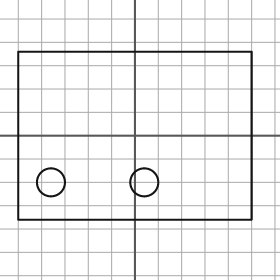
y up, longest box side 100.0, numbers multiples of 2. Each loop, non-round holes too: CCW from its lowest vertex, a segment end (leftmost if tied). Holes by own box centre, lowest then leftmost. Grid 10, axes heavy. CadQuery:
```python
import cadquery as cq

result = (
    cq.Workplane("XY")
    .moveTo(-50.0, -36.0)
    .lineTo(50.0, -36.0)
    .lineTo(50.0, 36.0)
    .lineTo(-50.0, 36.0)
    .close()
    .moveTo(-36.0, -20.0)
    .circle(6.0)
    .moveTo(4.0, -20.0)
    .circle(6.0)
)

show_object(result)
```